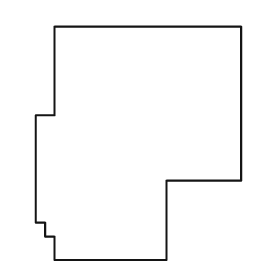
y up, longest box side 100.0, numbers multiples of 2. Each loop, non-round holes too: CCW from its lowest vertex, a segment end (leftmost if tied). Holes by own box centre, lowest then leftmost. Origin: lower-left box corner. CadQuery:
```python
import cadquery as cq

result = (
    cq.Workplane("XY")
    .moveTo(8.0, 0.0)
    .lineTo(56.0, 0.0)
    .lineTo(56.0, 34.0)
    .lineTo(88.0, 34.0)
    .lineTo(88.0, 100.0)
    .lineTo(8.0, 100.0)
    .lineTo(8.0, 62.0)
    .lineTo(0.0, 62.0)
    .lineTo(0.0, 16.0)
    .lineTo(4.0, 16.0)
    .lineTo(4.0, 10.0)
    .lineTo(8.0, 10.0)
    .close()
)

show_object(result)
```